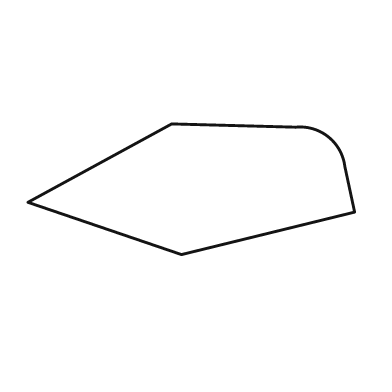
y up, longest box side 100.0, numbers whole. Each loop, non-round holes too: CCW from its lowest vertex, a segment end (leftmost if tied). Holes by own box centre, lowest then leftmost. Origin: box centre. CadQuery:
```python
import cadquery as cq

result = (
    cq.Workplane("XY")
    .moveTo(-3.0, -20.0)
    .lineTo(50.0, -7.0)
    .lineTo(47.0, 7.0)
    .threePointArc((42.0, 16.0), (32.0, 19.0))
    .lineTo(-6.0, 20.0)
    .lineTo(-50.0, -4.0)
    .close()
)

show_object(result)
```